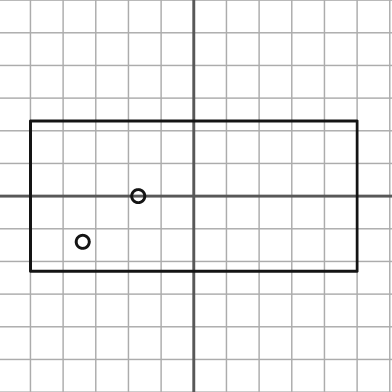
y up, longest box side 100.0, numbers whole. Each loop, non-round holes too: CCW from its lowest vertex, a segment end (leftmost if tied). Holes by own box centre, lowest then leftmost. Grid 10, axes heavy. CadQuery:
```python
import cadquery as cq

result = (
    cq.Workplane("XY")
    .moveTo(-50.0, -23.0)
    .lineTo(50.0, -23.0)
    .lineTo(50.0, 23.0)
    .lineTo(-50.0, 23.0)
    .close()
    .moveTo(-34.0, -14.0)
    .circle(2.0)
    .moveTo(-17.0, 0.0)
    .circle(2.0)
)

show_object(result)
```